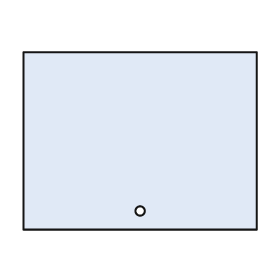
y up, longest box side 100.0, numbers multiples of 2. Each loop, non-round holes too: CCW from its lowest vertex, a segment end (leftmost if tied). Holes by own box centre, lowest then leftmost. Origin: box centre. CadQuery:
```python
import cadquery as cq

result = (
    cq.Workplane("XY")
    .moveTo(-50.0, -38.0)
    .lineTo(50.0, -38.0)
    .lineTo(50.0, 38.0)
    .lineTo(-50.0, 38.0)
    .close()
    .moveTo(0.0, -30.0)
    .circle(2.0)
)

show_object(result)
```